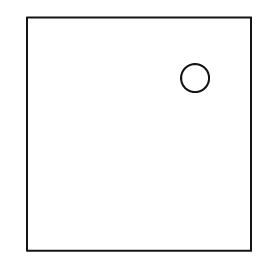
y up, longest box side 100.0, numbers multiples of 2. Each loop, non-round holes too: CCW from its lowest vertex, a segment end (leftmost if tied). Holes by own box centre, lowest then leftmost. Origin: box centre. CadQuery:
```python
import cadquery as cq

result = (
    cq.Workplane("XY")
    .moveTo(-48.0, -50.0)
    .lineTo(48.0, -50.0)
    .lineTo(48.0, 50.0)
    .lineTo(-48.0, 50.0)
    .close()
    .moveTo(24.0, 24.0)
    .circle(6.0)
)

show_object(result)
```